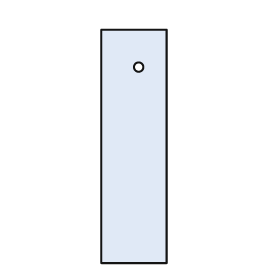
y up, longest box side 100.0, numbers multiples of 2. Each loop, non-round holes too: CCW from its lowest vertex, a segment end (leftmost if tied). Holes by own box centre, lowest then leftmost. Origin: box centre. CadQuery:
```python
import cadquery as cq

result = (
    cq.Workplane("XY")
    .moveTo(-14.0, -50.0)
    .lineTo(14.0, -50.0)
    .lineTo(14.0, 50.0)
    .lineTo(-14.0, 50.0)
    .close()
    .moveTo(2.0, 34.0)
    .circle(2.0)
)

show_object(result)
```